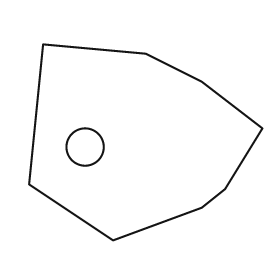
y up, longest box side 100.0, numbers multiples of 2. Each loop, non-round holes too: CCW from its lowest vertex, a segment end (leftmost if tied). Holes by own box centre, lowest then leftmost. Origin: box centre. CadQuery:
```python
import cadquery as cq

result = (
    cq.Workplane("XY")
    .moveTo(-14.0, -42.0)
    .lineTo(24.0, -28.0)
    .lineTo(34.0, -20.0)
    .lineTo(50.0, 6.0)
    .lineTo(24.0, 26.0)
    .lineTo(0.0, 38.0)
    .lineTo(-44.0, 42.0)
    .lineTo(-50.0, -18.0)
    .close()
    .moveTo(-26.0, -2.0)
    .circle(8.0)
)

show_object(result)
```